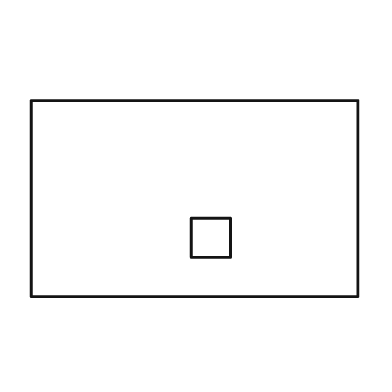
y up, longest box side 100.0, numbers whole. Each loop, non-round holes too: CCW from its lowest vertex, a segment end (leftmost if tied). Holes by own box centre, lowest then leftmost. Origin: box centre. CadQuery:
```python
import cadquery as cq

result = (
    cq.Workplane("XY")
    .moveTo(-50.0, -30.0)
    .lineTo(50.0, -30.0)
    .lineTo(50.0, 30.0)
    .lineTo(-50.0, 30.0)
    .close()
    .moveTo(-1.0, -18.0)
    .lineTo(11.0, -18.0)
    .lineTo(11.0, -6.0)
    .lineTo(-1.0, -6.0)
    .close()
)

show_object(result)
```